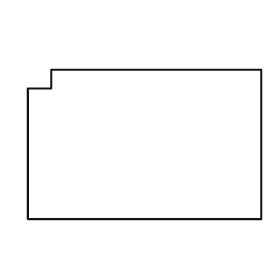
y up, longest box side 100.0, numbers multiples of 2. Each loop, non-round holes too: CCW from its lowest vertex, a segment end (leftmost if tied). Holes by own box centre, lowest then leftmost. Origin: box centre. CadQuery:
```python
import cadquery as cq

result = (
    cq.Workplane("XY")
    .moveTo(-50.0, -32.0)
    .lineTo(50.0, -32.0)
    .lineTo(50.0, 32.0)
    .lineTo(-40.0, 32.0)
    .lineTo(-40.0, 24.0)
    .lineTo(-50.0, 24.0)
    .close()
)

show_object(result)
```